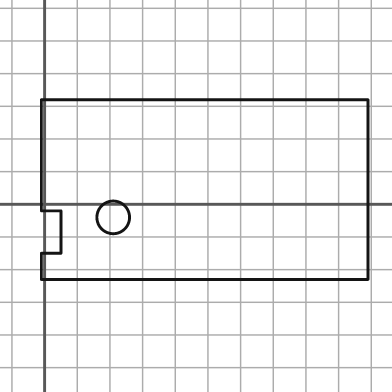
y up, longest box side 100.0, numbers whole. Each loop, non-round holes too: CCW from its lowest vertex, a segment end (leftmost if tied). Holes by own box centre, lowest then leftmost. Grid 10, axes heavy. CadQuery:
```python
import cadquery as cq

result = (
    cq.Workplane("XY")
    .moveTo(-1.0, -23.0)
    .lineTo(99.0, -23.0)
    .lineTo(99.0, 32.0)
    .lineTo(-1.0, 32.0)
    .lineTo(-1.0, -2.0)
    .lineTo(5.0, -2.0)
    .lineTo(5.0, -15.0)
    .lineTo(-1.0, -15.0)
    .close()
    .moveTo(21.0, -4.0)
    .circle(5.0)
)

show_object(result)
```